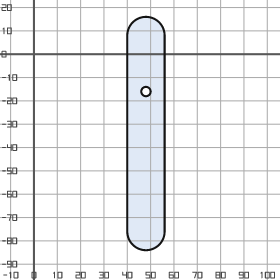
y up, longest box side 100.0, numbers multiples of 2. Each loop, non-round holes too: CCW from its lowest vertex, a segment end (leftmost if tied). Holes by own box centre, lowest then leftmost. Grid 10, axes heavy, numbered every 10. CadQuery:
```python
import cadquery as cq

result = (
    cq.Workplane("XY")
    .moveTo(40.0, -76.0)
    .threePointArc((48.0, -84.0), (56.0, -76.0))
    .lineTo(56.0, 8.0)
    .threePointArc((48.0, 16.0), (40.0, 8.0))
    .close()
    .moveTo(48.0, -16.0)
    .circle(2.0)
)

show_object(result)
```